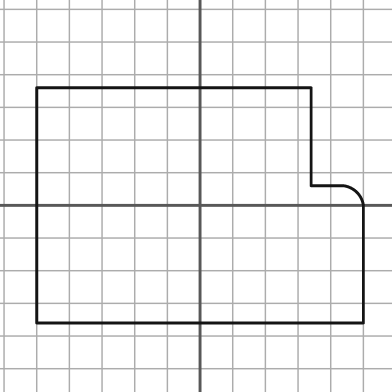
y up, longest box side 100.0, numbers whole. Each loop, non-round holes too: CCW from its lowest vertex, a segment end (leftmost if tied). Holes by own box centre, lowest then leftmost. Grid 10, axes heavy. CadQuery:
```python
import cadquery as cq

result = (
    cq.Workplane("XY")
    .moveTo(-50.0, -36.0)
    .lineTo(50.0, -36.0)
    .lineTo(50.0, 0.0)
    .threePointArc((48.0, 4.0), (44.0, 6.0))
    .lineTo(34.0, 6.0)
    .lineTo(34.0, 36.0)
    .lineTo(-50.0, 36.0)
    .close()
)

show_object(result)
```